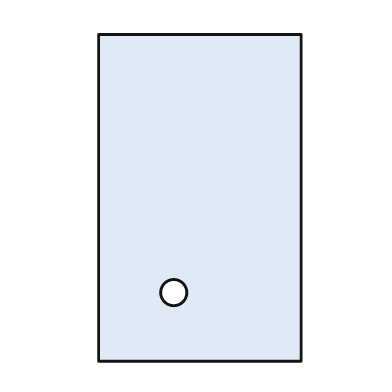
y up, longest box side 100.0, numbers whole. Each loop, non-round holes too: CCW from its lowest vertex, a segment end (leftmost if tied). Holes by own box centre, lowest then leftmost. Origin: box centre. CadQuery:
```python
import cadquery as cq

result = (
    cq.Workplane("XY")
    .moveTo(-31.0, -50.0)
    .lineTo(31.0, -50.0)
    .lineTo(31.0, 50.0)
    .lineTo(-31.0, 50.0)
    .close()
    .moveTo(-8.0, -29.0)
    .circle(4.0)
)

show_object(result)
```